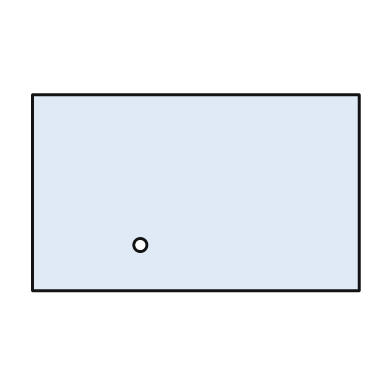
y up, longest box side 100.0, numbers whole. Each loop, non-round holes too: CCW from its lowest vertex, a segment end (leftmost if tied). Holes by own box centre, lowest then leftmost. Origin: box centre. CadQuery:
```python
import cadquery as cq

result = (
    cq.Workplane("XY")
    .moveTo(-50.0, -30.0)
    .lineTo(50.0, -30.0)
    .lineTo(50.0, 30.0)
    .lineTo(-50.0, 30.0)
    .close()
    .moveTo(-17.0, -16.0)
    .circle(2.0)
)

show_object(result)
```